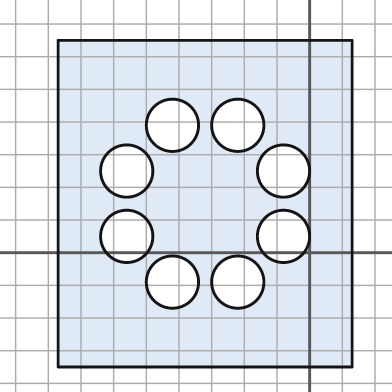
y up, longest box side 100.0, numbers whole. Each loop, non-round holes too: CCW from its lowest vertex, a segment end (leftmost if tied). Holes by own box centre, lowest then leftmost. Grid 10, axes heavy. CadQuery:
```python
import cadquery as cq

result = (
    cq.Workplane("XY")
    .moveTo(-77.0, -35.0)
    .lineTo(13.0, -35.0)
    .lineTo(13.0, 65.0)
    .lineTo(-77.0, 65.0)
    .close()
    .moveTo(-42.0, -9.0)
    .circle(8.0)
    .moveTo(-22.0, -9.0)
    .circle(8.0)
    .moveTo(-56.0, 5.0)
    .circle(8.0)
    .moveTo(-8.0, 5.0)
    .circle(8.0)
    .moveTo(-56.0, 25.0)
    .circle(8.0)
    .moveTo(-8.0, 25.0)
    .circle(8.0)
    .moveTo(-42.0, 39.0)
    .circle(8.0)
    .moveTo(-22.0, 39.0)
    .circle(8.0)
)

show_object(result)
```